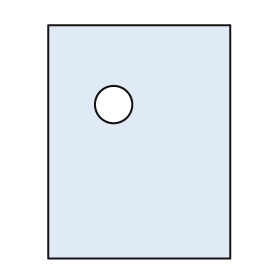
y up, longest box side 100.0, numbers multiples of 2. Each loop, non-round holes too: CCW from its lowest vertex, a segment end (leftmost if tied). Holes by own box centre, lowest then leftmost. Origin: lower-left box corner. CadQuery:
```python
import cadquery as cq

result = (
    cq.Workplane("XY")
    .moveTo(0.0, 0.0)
    .lineTo(78.0, 0.0)
    .lineTo(78.0, 100.0)
    .lineTo(0.0, 100.0)
    .close()
    .moveTo(28.0, 66.0)
    .circle(8.0)
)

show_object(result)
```